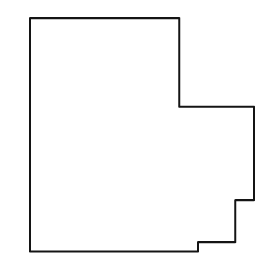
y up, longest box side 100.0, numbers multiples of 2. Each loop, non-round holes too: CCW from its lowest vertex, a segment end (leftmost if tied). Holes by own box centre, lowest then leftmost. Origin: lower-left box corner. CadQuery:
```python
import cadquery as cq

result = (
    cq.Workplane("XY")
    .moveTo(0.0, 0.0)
    .lineTo(72.0, 0.0)
    .lineTo(72.0, 4.0)
    .lineTo(88.0, 4.0)
    .lineTo(88.0, 22.0)
    .lineTo(96.0, 22.0)
    .lineTo(96.0, 62.0)
    .lineTo(64.0, 62.0)
    .lineTo(64.0, 100.0)
    .lineTo(0.0, 100.0)
    .close()
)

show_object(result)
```